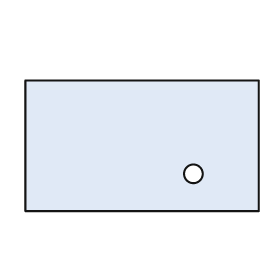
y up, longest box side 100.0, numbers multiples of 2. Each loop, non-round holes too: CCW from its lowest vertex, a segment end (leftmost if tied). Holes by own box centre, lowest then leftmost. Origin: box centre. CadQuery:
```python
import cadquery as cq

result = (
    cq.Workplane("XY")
    .moveTo(-50.0, -28.0)
    .lineTo(50.0, -28.0)
    .lineTo(50.0, 28.0)
    .lineTo(-50.0, 28.0)
    .close()
    .moveTo(22.0, -12.0)
    .circle(4.0)
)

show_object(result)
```